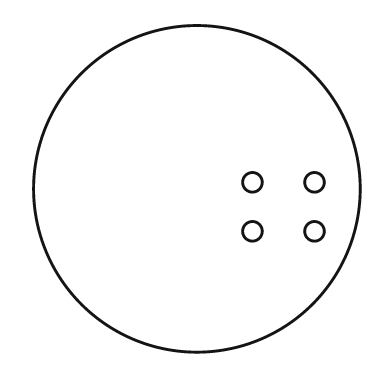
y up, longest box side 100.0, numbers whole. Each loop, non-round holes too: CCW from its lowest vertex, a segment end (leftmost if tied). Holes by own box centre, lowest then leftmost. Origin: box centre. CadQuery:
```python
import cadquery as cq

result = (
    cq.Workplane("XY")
    .moveTo(0.0, 0.0)
    .circle(50.0)
    .moveTo(17.0, -13.0)
    .circle(3.0)
    .moveTo(36.0, -13.0)
    .circle(3.0)
    .moveTo(17.0, 2.0)
    .circle(3.0)
    .moveTo(36.0, 2.0)
    .circle(3.0)
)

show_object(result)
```